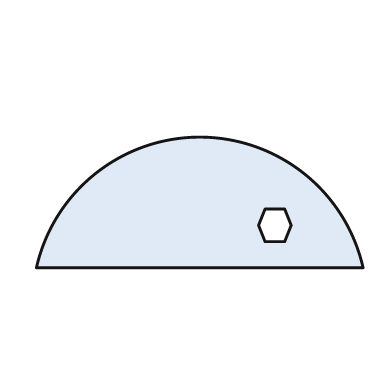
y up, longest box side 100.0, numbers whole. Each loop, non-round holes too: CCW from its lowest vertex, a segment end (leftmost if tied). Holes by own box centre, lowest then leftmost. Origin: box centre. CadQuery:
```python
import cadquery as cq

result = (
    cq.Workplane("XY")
    .moveTo(-50.0, -20.0)
    .lineTo(50.0, -20.0)
    .threePointArc((0.0, 20.0), (-50.0, -20.0))
    .close()
    .moveTo(20.0, -12.0)
    .lineTo(26.0, -12.0)
    .lineTo(28.0, -7.0)
    .lineTo(26.0, -2.0)
    .lineTo(20.0, -2.0)
    .lineTo(18.0, -7.0)
    .close()
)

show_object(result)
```